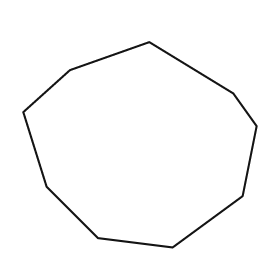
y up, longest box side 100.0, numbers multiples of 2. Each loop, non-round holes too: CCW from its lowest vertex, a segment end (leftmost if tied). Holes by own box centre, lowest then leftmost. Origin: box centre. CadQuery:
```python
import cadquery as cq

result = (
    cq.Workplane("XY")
    .moveTo(14.0, -44.0)
    .lineTo(44.0, -22.0)
    .lineTo(50.0, 8.0)
    .lineTo(40.0, 22.0)
    .lineTo(4.0, 44.0)
    .lineTo(-30.0, 32.0)
    .lineTo(-50.0, 14.0)
    .lineTo(-40.0, -18.0)
    .lineTo(-18.0, -40.0)
    .close()
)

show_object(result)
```